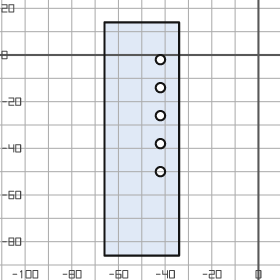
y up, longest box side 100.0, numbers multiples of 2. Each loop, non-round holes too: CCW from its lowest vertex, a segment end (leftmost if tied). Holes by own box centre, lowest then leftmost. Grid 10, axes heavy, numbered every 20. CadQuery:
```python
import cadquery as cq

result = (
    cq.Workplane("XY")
    .moveTo(-66.0, -86.0)
    .lineTo(-34.0, -86.0)
    .lineTo(-34.0, 14.0)
    .lineTo(-66.0, 14.0)
    .close()
    .moveTo(-42.0, -50.0)
    .circle(2.0)
    .moveTo(-42.0, -38.0)
    .circle(2.0)
    .moveTo(-42.0, -26.0)
    .circle(2.0)
    .moveTo(-42.0, -14.0)
    .circle(2.0)
    .moveTo(-42.0, -2.0)
    .circle(2.0)
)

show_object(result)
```